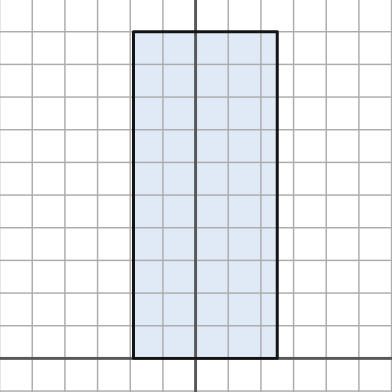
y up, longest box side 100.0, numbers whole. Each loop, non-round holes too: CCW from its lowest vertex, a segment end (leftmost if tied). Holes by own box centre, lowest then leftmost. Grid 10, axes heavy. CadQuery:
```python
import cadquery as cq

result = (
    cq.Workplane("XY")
    .moveTo(-19.0, 0.0)
    .lineTo(25.0, 0.0)
    .lineTo(25.0, 100.0)
    .lineTo(-19.0, 100.0)
    .close()
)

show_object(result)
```